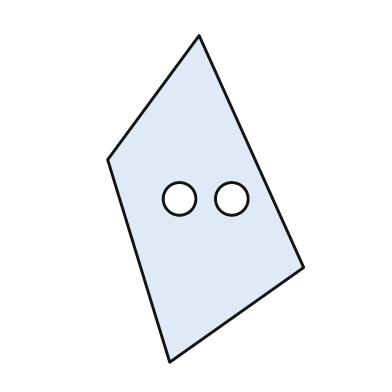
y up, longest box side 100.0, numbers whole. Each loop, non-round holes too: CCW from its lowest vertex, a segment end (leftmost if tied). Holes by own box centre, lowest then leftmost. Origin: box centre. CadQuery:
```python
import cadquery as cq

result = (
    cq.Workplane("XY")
    .moveTo(-11.0, -50.0)
    .lineTo(30.0, -21.0)
    .lineTo(-2.0, 50.0)
    .lineTo(-30.0, 12.0)
    .close()
    .moveTo(-8.0, 0.0)
    .circle(5.0)
    .moveTo(8.0, 0.0)
    .circle(5.0)
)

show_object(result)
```